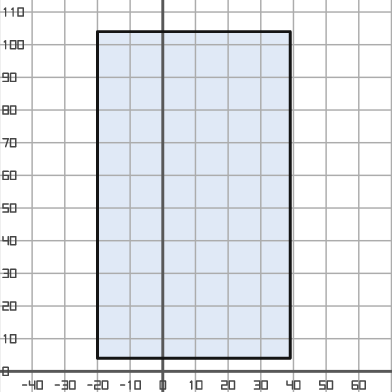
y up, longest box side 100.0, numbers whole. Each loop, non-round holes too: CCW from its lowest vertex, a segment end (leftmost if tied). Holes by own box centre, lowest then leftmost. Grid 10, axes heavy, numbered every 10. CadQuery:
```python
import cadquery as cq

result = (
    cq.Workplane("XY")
    .moveTo(-20.0, 4.0)
    .lineTo(39.0, 4.0)
    .lineTo(39.0, 104.0)
    .lineTo(-20.0, 104.0)
    .close()
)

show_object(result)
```